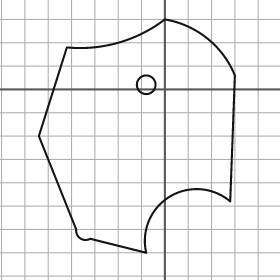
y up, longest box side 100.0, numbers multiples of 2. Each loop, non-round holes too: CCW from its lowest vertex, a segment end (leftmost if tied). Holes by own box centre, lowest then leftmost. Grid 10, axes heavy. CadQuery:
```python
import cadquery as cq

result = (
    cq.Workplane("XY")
    .moveTo(-8.0, -70.0)
    .threePointArc((2.0, -46.0), (28.0, -48.0))
    .lineTo(30.0, 6.0)
    .threePointArc((18.0, 22.0), (0.0, 30.0))
    .threePointArc((-20.0, 20.0), (-42.0, 18.0))
    .lineTo(-54.0, -20.0)
    .lineTo(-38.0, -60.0)
    .threePointArc((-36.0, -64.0), (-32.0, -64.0))
    .close()
    .moveTo(-8.0, 2.0)
    .circle(4.0)
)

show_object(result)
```